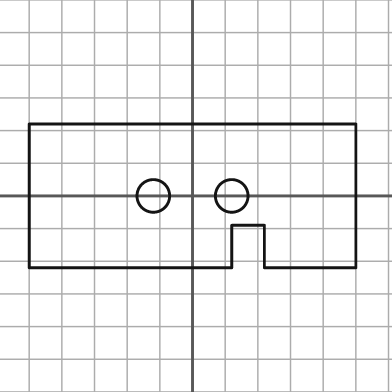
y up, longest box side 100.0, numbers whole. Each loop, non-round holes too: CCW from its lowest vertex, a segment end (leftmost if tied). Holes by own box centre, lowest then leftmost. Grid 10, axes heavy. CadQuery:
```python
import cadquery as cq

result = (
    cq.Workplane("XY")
    .moveTo(-50.0, -22.0)
    .lineTo(12.0, -22.0)
    .lineTo(12.0, -9.0)
    .lineTo(22.0, -9.0)
    .lineTo(22.0, -22.0)
    .lineTo(50.0, -22.0)
    .lineTo(50.0, 22.0)
    .lineTo(-50.0, 22.0)
    .close()
    .moveTo(-12.0, 0.0)
    .circle(5.0)
    .moveTo(12.0, 0.0)
    .circle(5.0)
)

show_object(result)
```